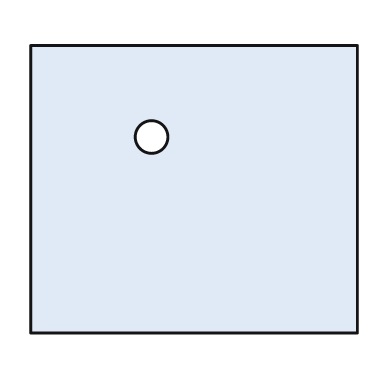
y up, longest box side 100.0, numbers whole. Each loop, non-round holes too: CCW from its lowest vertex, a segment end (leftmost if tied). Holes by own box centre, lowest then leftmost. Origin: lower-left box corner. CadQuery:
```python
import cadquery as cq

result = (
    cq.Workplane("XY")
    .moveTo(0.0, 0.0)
    .lineTo(100.0, 0.0)
    .lineTo(100.0, 88.0)
    .lineTo(0.0, 88.0)
    .close()
    .moveTo(37.0, 60.0)
    .circle(5.0)
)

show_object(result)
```